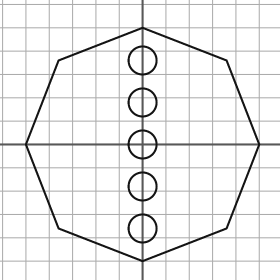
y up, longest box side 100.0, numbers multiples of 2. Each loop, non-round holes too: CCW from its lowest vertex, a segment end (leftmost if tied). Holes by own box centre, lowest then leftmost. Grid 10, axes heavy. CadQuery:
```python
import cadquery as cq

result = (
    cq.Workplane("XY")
    .moveTo(0.0, -50.0)
    .lineTo(36.0, -36.0)
    .lineTo(50.0, 0.0)
    .lineTo(36.0, 36.0)
    .lineTo(0.0, 50.0)
    .lineTo(-36.0, 36.0)
    .lineTo(-50.0, 0.0)
    .lineTo(-36.0, -36.0)
    .close()
    .moveTo(0.0, -36.0)
    .circle(6.0)
    .moveTo(0.0, -18.0)
    .circle(6.0)
    .moveTo(0.0, 0.0)
    .circle(6.0)
    .moveTo(0.0, 18.0)
    .circle(6.0)
    .moveTo(0.0, 36.0)
    .circle(6.0)
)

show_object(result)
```